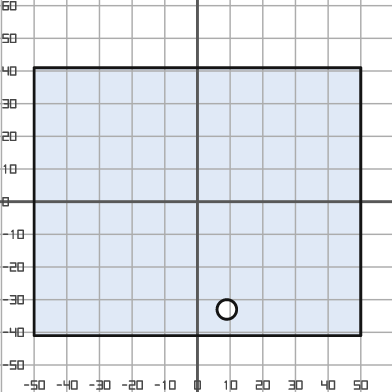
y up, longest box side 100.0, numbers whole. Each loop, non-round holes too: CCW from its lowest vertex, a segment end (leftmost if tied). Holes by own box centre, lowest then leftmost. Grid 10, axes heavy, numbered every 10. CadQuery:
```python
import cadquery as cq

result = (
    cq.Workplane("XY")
    .moveTo(-50.0, -41.0)
    .lineTo(50.0, -41.0)
    .lineTo(50.0, 41.0)
    .lineTo(-50.0, 41.0)
    .close()
    .moveTo(9.0, -33.0)
    .circle(3.0)
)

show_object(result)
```